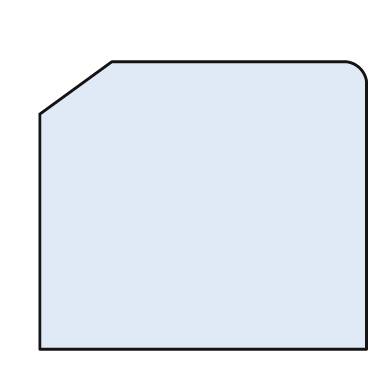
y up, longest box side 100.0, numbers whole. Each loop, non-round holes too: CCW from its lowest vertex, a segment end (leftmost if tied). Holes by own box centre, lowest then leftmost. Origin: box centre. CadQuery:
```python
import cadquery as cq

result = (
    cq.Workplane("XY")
    .moveTo(-50.0, -44.0)
    .lineTo(50.0, -44.0)
    .lineTo(50.0, 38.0)
    .threePointArc((48.0, 42.0), (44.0, 44.0))
    .lineTo(-28.0, 44.0)
    .lineTo(-50.0, 28.0)
    .close()
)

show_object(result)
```